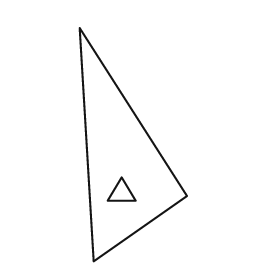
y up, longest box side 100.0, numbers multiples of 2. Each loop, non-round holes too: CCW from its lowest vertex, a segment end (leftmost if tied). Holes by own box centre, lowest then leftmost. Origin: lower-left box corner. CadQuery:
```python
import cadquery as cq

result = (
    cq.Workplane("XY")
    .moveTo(6.0, 0.0)
    .lineTo(46.0, 28.0)
    .lineTo(0.0, 100.0)
    .close()
    .moveTo(12.0, 26.0)
    .lineTo(24.0, 26.0)
    .lineTo(18.0, 36.0)
    .close()
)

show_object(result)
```